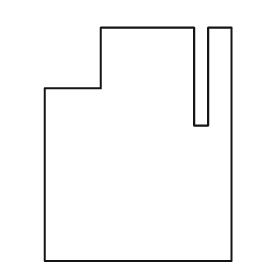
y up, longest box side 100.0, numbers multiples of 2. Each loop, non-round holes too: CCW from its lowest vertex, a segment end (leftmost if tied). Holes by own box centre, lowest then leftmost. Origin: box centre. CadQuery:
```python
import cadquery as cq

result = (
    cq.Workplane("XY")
    .moveTo(-40.0, -50.0)
    .lineTo(40.0, -50.0)
    .lineTo(40.0, 50.0)
    .lineTo(30.0, 50.0)
    .lineTo(30.0, 8.0)
    .lineTo(24.0, 8.0)
    .lineTo(24.0, 50.0)
    .lineTo(-16.0, 50.0)
    .lineTo(-16.0, 24.0)
    .lineTo(-40.0, 24.0)
    .close()
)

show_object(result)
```